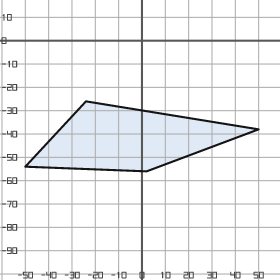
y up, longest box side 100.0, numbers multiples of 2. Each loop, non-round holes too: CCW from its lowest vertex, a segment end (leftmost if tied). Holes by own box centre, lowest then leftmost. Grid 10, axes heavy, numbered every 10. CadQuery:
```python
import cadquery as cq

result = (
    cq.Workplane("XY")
    .moveTo(2.0, -56.0)
    .lineTo(50.0, -38.0)
    .lineTo(-24.0, -26.0)
    .lineTo(-50.0, -54.0)
    .close()
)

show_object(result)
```